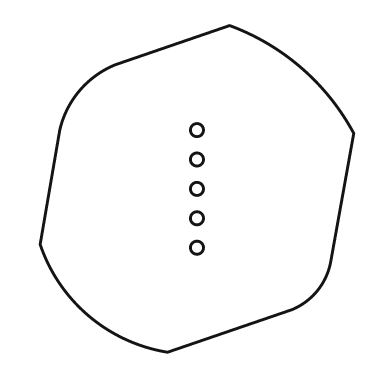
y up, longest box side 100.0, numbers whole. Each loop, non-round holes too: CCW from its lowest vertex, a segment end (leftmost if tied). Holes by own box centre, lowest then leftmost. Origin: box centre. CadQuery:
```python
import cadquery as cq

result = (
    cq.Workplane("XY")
    .moveTo(-9.0, -50.0)
    .lineTo(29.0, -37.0)
    .threePointArc((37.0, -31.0), (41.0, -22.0))
    .lineTo(48.0, 17.0)
    .threePointArc((32.0, 37.0), (10.0, 50.0))
    .lineTo(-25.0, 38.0)
    .threePointArc((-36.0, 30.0), (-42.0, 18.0))
    .lineTo(-48.0, -17.0)
    .threePointArc((-33.0, -39.0), (-9.0, -50.0))
    .close()
    .moveTo(0.0, -18.0)
    .circle(2.0)
    .moveTo(0.0, -9.0)
    .circle(2.0)
    .moveTo(0.0, 0.0)
    .circle(2.0)
    .moveTo(0.0, 9.0)
    .circle(2.0)
    .moveTo(0.0, 18.0)
    .circle(2.0)
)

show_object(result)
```